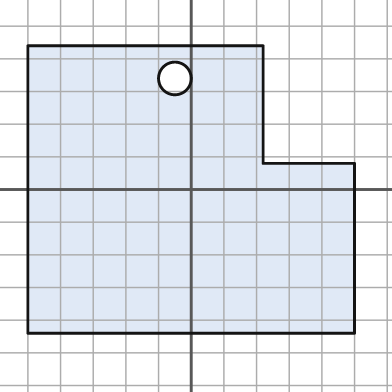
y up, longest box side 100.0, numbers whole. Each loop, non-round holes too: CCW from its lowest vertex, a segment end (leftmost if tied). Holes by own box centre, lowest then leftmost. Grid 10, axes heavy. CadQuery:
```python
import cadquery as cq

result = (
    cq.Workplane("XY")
    .moveTo(-50.0, -44.0)
    .lineTo(50.0, -44.0)
    .lineTo(50.0, 8.0)
    .lineTo(22.0, 8.0)
    .lineTo(22.0, 44.0)
    .lineTo(-50.0, 44.0)
    .close()
    .moveTo(-5.0, 34.0)
    .circle(5.0)
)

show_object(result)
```